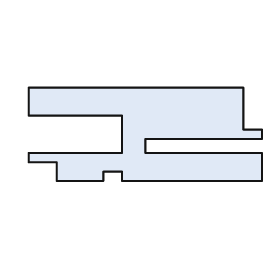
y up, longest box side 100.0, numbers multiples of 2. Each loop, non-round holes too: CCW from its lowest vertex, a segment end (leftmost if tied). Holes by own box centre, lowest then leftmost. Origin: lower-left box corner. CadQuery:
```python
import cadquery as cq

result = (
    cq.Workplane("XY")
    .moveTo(12.0, 0.0)
    .lineTo(32.0, 0.0)
    .lineTo(32.0, 4.0)
    .lineTo(40.0, 4.0)
    .lineTo(40.0, 0.0)
    .lineTo(100.0, 0.0)
    .lineTo(100.0, 12.0)
    .lineTo(50.0, 12.0)
    .lineTo(50.0, 18.0)
    .lineTo(100.0, 18.0)
    .lineTo(100.0, 22.0)
    .lineTo(92.0, 22.0)
    .lineTo(92.0, 40.0)
    .lineTo(0.0, 40.0)
    .lineTo(0.0, 28.0)
    .lineTo(40.0, 28.0)
    .lineTo(40.0, 12.0)
    .lineTo(0.0, 12.0)
    .lineTo(0.0, 8.0)
    .lineTo(12.0, 8.0)
    .close()
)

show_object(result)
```